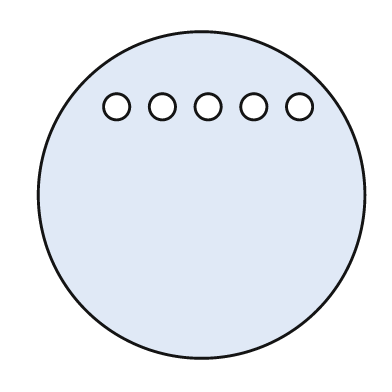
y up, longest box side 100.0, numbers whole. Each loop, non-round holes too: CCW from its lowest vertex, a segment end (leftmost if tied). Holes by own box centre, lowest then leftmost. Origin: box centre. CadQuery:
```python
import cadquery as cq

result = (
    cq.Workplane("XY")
    .moveTo(0.0, 0.0)
    .circle(50.0)
    .moveTo(-26.0, 27.0)
    .circle(4.0)
    .moveTo(-12.0, 27.0)
    .circle(4.0)
    .moveTo(2.0, 27.0)
    .circle(4.0)
    .moveTo(16.0, 27.0)
    .circle(4.0)
    .moveTo(30.0, 27.0)
    .circle(4.0)
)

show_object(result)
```